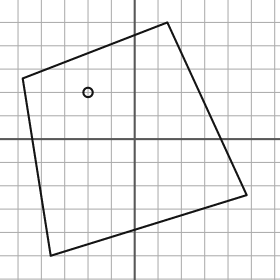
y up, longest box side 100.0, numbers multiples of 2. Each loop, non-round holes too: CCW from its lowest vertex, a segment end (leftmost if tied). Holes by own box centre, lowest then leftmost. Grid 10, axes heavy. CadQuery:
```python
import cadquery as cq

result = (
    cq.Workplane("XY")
    .moveTo(-36.0, -50.0)
    .lineTo(48.0, -24.0)
    .lineTo(14.0, 50.0)
    .lineTo(-48.0, 26.0)
    .close()
    .moveTo(-20.0, 20.0)
    .circle(2.0)
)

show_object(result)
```